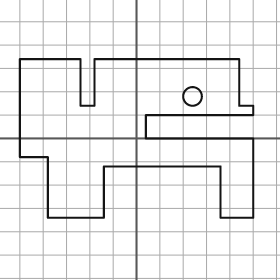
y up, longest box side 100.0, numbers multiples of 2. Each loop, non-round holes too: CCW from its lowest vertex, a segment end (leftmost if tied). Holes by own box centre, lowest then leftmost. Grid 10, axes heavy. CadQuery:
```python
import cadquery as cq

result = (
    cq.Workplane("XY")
    .moveTo(-38.0, -34.0)
    .lineTo(-14.0, -34.0)
    .lineTo(-14.0, -12.0)
    .lineTo(36.0, -12.0)
    .lineTo(36.0, -34.0)
    .lineTo(50.0, -34.0)
    .lineTo(50.0, 0.0)
    .lineTo(4.0, 0.0)
    .lineTo(4.0, 10.0)
    .lineTo(50.0, 10.0)
    .lineTo(50.0, 14.0)
    .lineTo(44.0, 14.0)
    .lineTo(44.0, 34.0)
    .lineTo(-18.0, 34.0)
    .lineTo(-18.0, 14.0)
    .lineTo(-24.0, 14.0)
    .lineTo(-24.0, 34.0)
    .lineTo(-50.0, 34.0)
    .lineTo(-50.0, -8.0)
    .lineTo(-38.0, -8.0)
    .close()
    .moveTo(24.0, 18.0)
    .circle(4.0)
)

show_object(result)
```